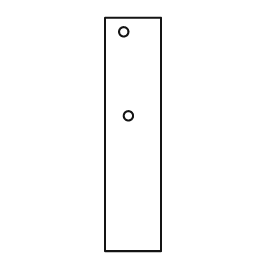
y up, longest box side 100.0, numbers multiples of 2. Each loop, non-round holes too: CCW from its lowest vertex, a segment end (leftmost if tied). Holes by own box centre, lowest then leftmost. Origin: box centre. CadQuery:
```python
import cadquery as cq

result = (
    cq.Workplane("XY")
    .moveTo(-12.0, -50.0)
    .lineTo(12.0, -50.0)
    .lineTo(12.0, 50.0)
    .lineTo(-12.0, 50.0)
    .close()
    .moveTo(-2.0, 8.0)
    .circle(2.0)
    .moveTo(-4.0, 44.0)
    .circle(2.0)
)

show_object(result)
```